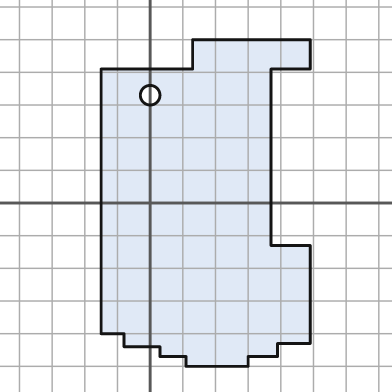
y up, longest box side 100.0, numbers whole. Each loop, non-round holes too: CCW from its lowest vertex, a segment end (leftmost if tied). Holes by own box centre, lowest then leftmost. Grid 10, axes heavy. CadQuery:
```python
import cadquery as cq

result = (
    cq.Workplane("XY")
    .moveTo(11.0, -50.0)
    .lineTo(30.0, -50.0)
    .lineTo(30.0, -47.0)
    .lineTo(39.0, -47.0)
    .lineTo(39.0, -43.0)
    .lineTo(49.0, -43.0)
    .lineTo(49.0, -13.0)
    .lineTo(37.0, -13.0)
    .lineTo(37.0, 41.0)
    .lineTo(49.0, 41.0)
    .lineTo(49.0, 50.0)
    .lineTo(13.0, 50.0)
    .lineTo(13.0, 41.0)
    .lineTo(-15.0, 41.0)
    .lineTo(-15.0, -40.0)
    .lineTo(-8.0, -40.0)
    .lineTo(-8.0, -44.0)
    .lineTo(3.0, -44.0)
    .lineTo(3.0, -47.0)
    .lineTo(11.0, -47.0)
    .close()
    .moveTo(0.0, 33.0)
    .circle(3.0)
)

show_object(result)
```